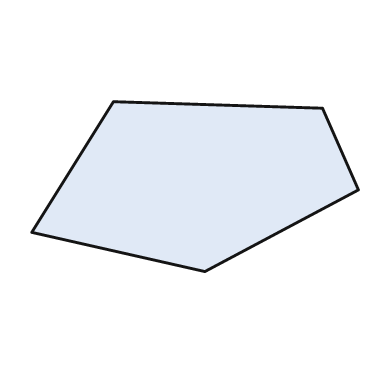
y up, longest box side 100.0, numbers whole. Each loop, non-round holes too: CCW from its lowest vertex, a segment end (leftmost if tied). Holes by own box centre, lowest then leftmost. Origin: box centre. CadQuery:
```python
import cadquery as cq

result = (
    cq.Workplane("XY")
    .moveTo(3.0, -26.0)
    .lineTo(50.0, -1.0)
    .lineTo(39.0, 24.0)
    .lineTo(-25.0, 26.0)
    .lineTo(-50.0, -14.0)
    .close()
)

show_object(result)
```